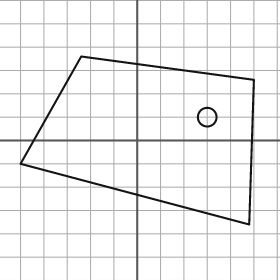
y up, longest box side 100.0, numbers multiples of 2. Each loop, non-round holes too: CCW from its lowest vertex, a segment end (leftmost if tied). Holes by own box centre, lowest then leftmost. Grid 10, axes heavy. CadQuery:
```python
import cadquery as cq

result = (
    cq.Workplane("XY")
    .moveTo(48.0, -36.0)
    .lineTo(50.0, 26.0)
    .lineTo(-24.0, 36.0)
    .lineTo(-50.0, -10.0)
    .close()
    .moveTo(30.0, 10.0)
    .circle(4.0)
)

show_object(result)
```